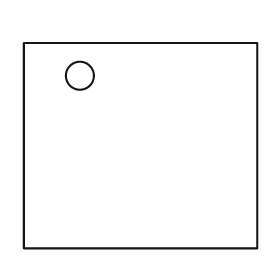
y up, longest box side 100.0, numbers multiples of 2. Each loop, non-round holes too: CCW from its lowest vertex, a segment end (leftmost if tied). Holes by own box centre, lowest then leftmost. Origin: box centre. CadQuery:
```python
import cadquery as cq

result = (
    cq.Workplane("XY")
    .moveTo(-50.0, -44.0)
    .lineTo(50.0, -44.0)
    .lineTo(50.0, 44.0)
    .lineTo(-50.0, 44.0)
    .close()
    .moveTo(-26.0, 30.0)
    .circle(6.0)
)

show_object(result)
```